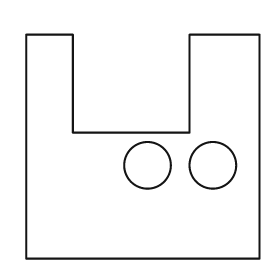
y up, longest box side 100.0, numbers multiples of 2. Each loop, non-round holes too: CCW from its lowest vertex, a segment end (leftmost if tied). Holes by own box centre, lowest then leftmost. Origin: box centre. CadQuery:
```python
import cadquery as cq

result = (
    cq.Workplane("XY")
    .moveTo(-50.0, -48.0)
    .lineTo(50.0, -48.0)
    .lineTo(50.0, 48.0)
    .lineTo(20.0, 48.0)
    .lineTo(20.0, 6.0)
    .lineTo(-30.0, 6.0)
    .lineTo(-30.0, 48.0)
    .lineTo(-50.0, 48.0)
    .close()
    .moveTo(2.0, -8.0)
    .circle(10.0)
    .moveTo(30.0, -8.0)
    .circle(10.0)
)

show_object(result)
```